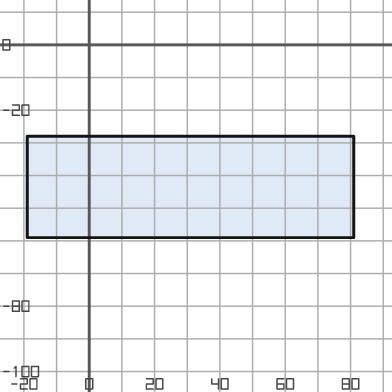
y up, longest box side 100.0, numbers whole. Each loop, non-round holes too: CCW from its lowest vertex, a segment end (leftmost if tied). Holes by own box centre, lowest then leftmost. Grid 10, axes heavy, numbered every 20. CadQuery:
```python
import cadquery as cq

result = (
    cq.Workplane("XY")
    .moveTo(-19.0, -59.0)
    .lineTo(81.0, -59.0)
    .lineTo(81.0, -28.0)
    .lineTo(-19.0, -28.0)
    .close()
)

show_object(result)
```